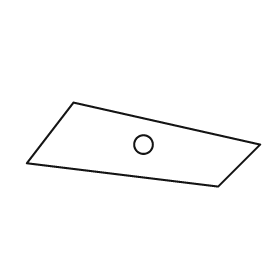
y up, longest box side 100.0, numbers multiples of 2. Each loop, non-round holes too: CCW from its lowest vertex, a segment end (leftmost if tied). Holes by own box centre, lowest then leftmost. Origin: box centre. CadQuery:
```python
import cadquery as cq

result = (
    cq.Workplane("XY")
    .moveTo(32.0, -18.0)
    .lineTo(50.0, 0.0)
    .lineTo(-30.0, 18.0)
    .lineTo(-50.0, -8.0)
    .close()
    .moveTo(0.0, 0.0)
    .circle(4.0)
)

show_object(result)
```